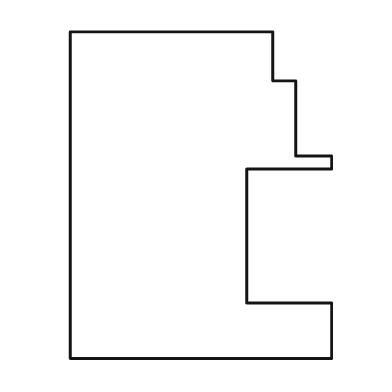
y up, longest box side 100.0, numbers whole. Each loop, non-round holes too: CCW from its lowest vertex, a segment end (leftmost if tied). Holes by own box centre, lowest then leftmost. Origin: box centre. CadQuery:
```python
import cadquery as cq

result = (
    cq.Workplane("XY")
    .moveTo(-40.0, -50.0)
    .lineTo(40.0, -50.0)
    .lineTo(40.0, -33.0)
    .lineTo(14.0, -33.0)
    .lineTo(14.0, 8.0)
    .lineTo(40.0, 8.0)
    .lineTo(40.0, 12.0)
    .lineTo(29.0, 12.0)
    .lineTo(29.0, 35.0)
    .lineTo(22.0, 35.0)
    .lineTo(22.0, 50.0)
    .lineTo(-40.0, 50.0)
    .close()
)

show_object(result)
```